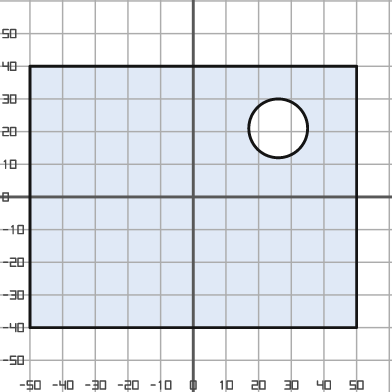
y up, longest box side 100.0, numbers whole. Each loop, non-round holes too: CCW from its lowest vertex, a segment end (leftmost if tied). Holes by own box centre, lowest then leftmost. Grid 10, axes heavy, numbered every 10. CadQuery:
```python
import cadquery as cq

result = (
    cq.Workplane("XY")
    .moveTo(-50.0, -40.0)
    .lineTo(50.0, -40.0)
    .lineTo(50.0, 40.0)
    .lineTo(-50.0, 40.0)
    .close()
    .moveTo(26.0, 21.0)
    .circle(9.0)
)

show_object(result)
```